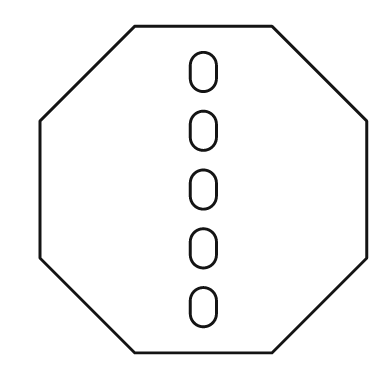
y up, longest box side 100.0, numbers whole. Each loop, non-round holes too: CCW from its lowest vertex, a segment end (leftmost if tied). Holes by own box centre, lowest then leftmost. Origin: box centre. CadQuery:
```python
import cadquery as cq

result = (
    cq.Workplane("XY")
    .moveTo(-21.0, -50.0)
    .lineTo(21.0, -50.0)
    .lineTo(50.0, -21.0)
    .lineTo(50.0, 21.0)
    .lineTo(21.0, 50.0)
    .lineTo(-21.0, 50.0)
    .lineTo(-50.0, 21.0)
    .lineTo(-50.0, -21.0)
    .close()
    .moveTo(-4.0, -38.0)
    .threePointArc((0.0, -42.0), (4.0, -38.0))
    .lineTo(4.0, -34.0)
    .threePointArc((0.0, -30.0), (-4.0, -34.0))
    .close()
    .moveTo(-4.0, -20.0)
    .threePointArc((0.0, -24.0), (4.0, -20.0))
    .lineTo(4.0, -16.0)
    .threePointArc((0.0, -12.0), (-4.0, -16.0))
    .close()
    .moveTo(-4.0, -2.0)
    .threePointArc((0.0, -6.0), (4.0, -2.0))
    .lineTo(4.0, 2.0)
    .threePointArc((0.0, 6.0), (-4.0, 2.0))
    .close()
    .moveTo(-4.0, 16.0)
    .threePointArc((0.0, 12.0), (4.0, 16.0))
    .lineTo(4.0, 20.0)
    .threePointArc((0.0, 24.0), (-4.0, 20.0))
    .close()
    .moveTo(-4.0, 34.0)
    .threePointArc((0.0, 30.0), (4.0, 34.0))
    .lineTo(4.0, 38.0)
    .threePointArc((0.0, 42.0), (-4.0, 38.0))
    .close()
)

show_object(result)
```